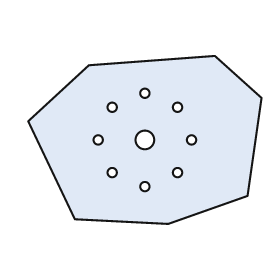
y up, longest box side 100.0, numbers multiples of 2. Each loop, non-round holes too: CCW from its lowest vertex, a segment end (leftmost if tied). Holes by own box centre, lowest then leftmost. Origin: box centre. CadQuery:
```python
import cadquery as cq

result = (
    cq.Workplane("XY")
    .moveTo(10.0, -36.0)
    .lineTo(44.0, -24.0)
    .lineTo(50.0, 18.0)
    .lineTo(30.0, 36.0)
    .lineTo(-24.0, 32.0)
    .lineTo(-50.0, 8.0)
    .lineTo(-30.0, -34.0)
    .close()
    .moveTo(0.0, -20.0)
    .circle(2.0)
    .moveTo(-14.0, -14.0)
    .circle(2.0)
    .moveTo(14.0, -14.0)
    .circle(2.0)
    .moveTo(-20.0, 0.0)
    .circle(2.0)
    .moveTo(0.0, 0.0)
    .circle(4.0)
    .moveTo(20.0, 0.0)
    .circle(2.0)
    .moveTo(-14.0, 14.0)
    .circle(2.0)
    .moveTo(14.0, 14.0)
    .circle(2.0)
    .moveTo(0.0, 20.0)
    .circle(2.0)
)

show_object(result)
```